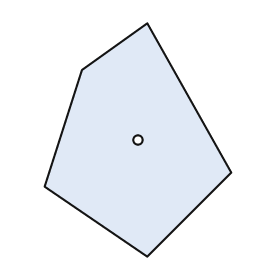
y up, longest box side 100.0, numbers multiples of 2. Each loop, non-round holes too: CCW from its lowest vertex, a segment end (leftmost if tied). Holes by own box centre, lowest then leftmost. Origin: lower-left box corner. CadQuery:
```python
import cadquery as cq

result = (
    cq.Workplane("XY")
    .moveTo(44.0, 0.0)
    .lineTo(80.0, 36.0)
    .lineTo(44.0, 100.0)
    .lineTo(16.0, 80.0)
    .lineTo(0.0, 30.0)
    .close()
    .moveTo(40.0, 50.0)
    .circle(2.0)
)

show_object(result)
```